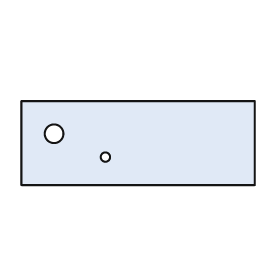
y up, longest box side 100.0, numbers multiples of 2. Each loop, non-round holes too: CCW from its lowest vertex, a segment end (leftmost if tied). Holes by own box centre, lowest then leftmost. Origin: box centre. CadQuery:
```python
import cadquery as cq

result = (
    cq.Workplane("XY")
    .moveTo(-50.0, -18.0)
    .lineTo(50.0, -18.0)
    .lineTo(50.0, 18.0)
    .lineTo(-50.0, 18.0)
    .close()
    .moveTo(-14.0, -6.0)
    .circle(2.0)
    .moveTo(-36.0, 4.0)
    .circle(4.0)
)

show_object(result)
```